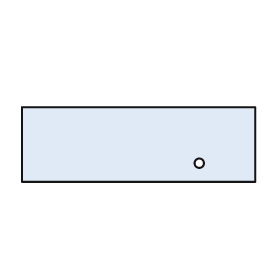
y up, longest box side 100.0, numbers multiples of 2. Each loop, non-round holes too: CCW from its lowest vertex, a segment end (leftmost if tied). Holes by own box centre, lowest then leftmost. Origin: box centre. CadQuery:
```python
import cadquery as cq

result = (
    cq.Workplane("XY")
    .moveTo(-50.0, -16.0)
    .lineTo(50.0, -16.0)
    .lineTo(50.0, 16.0)
    .lineTo(-50.0, 16.0)
    .close()
    .moveTo(26.0, -8.0)
    .circle(2.0)
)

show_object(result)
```